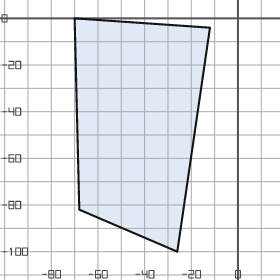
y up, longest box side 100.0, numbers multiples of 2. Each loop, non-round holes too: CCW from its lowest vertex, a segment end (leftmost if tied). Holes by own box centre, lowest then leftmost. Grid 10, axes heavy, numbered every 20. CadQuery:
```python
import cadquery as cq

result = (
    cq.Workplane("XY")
    .moveTo(-26.0, -100.0)
    .lineTo(-12.0, -4.0)
    .lineTo(-70.0, 0.0)
    .lineTo(-68.0, -82.0)
    .close()
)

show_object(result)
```